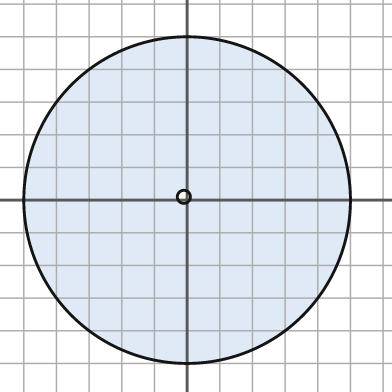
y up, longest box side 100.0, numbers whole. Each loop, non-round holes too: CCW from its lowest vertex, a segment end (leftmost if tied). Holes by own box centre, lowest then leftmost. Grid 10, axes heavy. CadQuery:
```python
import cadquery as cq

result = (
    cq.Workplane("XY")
    .moveTo(0.0, 0.0)
    .circle(50.0)
    .moveTo(-1.0, 1.0)
    .circle(2.0)
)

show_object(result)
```